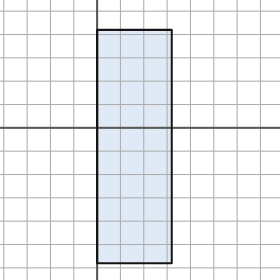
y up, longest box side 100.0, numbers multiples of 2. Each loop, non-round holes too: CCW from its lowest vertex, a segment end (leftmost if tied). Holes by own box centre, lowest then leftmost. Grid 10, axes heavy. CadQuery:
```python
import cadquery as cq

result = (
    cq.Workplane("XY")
    .moveTo(0.0, -58.0)
    .lineTo(32.0, -58.0)
    .lineTo(32.0, 42.0)
    .lineTo(0.0, 42.0)
    .close()
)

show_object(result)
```